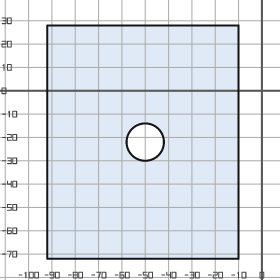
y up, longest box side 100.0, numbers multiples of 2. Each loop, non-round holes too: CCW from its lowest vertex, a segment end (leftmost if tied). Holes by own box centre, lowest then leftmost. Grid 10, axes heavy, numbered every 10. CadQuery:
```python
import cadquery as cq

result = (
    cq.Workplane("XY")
    .moveTo(-92.0, -72.0)
    .lineTo(-10.0, -72.0)
    .lineTo(-10.0, 28.0)
    .lineTo(-92.0, 28.0)
    .close()
    .moveTo(-50.0, -22.0)
    .circle(8.0)
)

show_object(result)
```